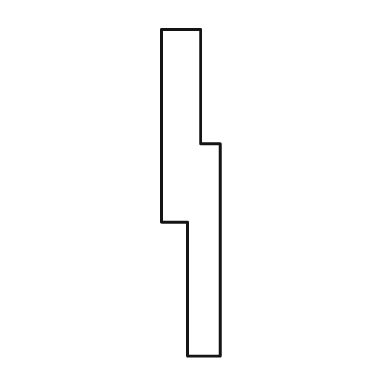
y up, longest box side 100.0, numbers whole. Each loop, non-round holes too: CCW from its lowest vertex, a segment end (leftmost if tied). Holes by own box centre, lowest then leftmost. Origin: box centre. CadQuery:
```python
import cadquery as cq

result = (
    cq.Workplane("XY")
    .moveTo(-1.0, -50.0)
    .lineTo(9.0, -50.0)
    .lineTo(9.0, 15.0)
    .lineTo(3.0, 15.0)
    .lineTo(3.0, 50.0)
    .lineTo(-9.0, 50.0)
    .lineTo(-9.0, -9.0)
    .lineTo(-1.0, -9.0)
    .close()
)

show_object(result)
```